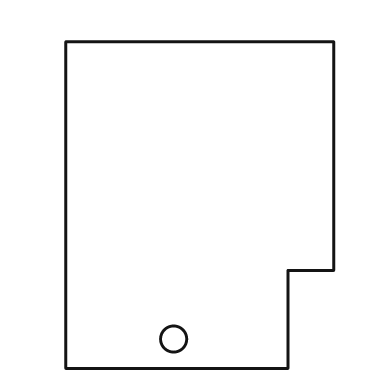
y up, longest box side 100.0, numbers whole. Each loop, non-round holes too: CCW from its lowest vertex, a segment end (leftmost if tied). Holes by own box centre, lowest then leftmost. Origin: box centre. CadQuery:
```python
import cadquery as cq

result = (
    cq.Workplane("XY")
    .moveTo(-41.0, -50.0)
    .lineTo(27.0, -50.0)
    .lineTo(27.0, -20.0)
    .lineTo(41.0, -20.0)
    .lineTo(41.0, 50.0)
    .lineTo(-41.0, 50.0)
    .close()
    .moveTo(-8.0, -41.0)
    .circle(4.0)
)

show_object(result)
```